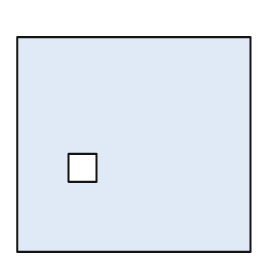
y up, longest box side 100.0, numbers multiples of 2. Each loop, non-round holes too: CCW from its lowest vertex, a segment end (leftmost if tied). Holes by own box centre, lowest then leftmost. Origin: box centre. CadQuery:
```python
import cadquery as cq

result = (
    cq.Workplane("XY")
    .moveTo(-50.0, -46.0)
    .lineTo(50.0, -46.0)
    .lineTo(50.0, 46.0)
    .lineTo(-50.0, 46.0)
    .close()
    .moveTo(-28.0, -16.0)
    .lineTo(-16.0, -16.0)
    .lineTo(-16.0, -4.0)
    .lineTo(-28.0, -4.0)
    .close()
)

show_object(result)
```